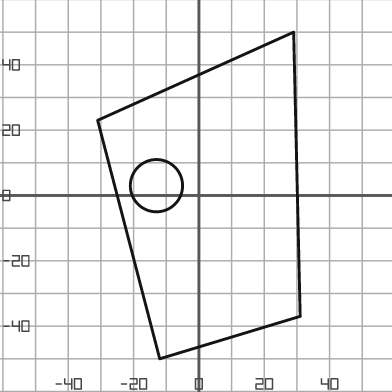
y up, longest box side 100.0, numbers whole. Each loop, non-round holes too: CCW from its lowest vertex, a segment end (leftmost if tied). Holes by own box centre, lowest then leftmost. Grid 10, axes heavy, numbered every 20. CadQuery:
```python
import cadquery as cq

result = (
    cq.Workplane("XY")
    .moveTo(-12.0, -50.0)
    .lineTo(31.0, -37.0)
    .lineTo(29.0, 50.0)
    .lineTo(-31.0, 23.0)
    .close()
    .moveTo(-13.0, 3.0)
    .circle(8.0)
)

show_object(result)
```